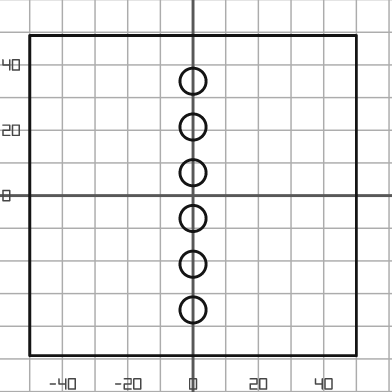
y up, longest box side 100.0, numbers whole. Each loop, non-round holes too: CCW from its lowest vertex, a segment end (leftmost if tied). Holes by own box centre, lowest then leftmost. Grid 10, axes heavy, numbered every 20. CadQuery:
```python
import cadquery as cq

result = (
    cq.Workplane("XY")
    .moveTo(-50.0, -49.0)
    .lineTo(50.0, -49.0)
    .lineTo(50.0, 49.0)
    .lineTo(-50.0, 49.0)
    .close()
    .moveTo(0.0, -35.0)
    .circle(4.0)
    .moveTo(0.0, -21.0)
    .circle(4.0)
    .moveTo(0.0, -7.0)
    .circle(4.0)
    .moveTo(0.0, 7.0)
    .circle(4.0)
    .moveTo(0.0, 21.0)
    .circle(4.0)
    .moveTo(0.0, 35.0)
    .circle(4.0)
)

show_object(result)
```